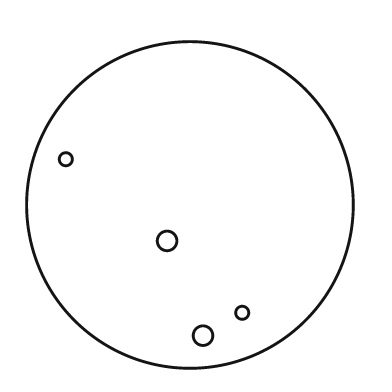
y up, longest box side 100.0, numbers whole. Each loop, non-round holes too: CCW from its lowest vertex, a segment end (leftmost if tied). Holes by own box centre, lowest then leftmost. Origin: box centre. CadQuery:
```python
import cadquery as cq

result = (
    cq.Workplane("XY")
    .moveTo(0.0, 0.0)
    .circle(50.0)
    .moveTo(4.0, -40.0)
    .circle(3.0)
    .moveTo(16.0, -33.0)
    .circle(2.0)
    .moveTo(-7.0, -11.0)
    .circle(3.0)
    .moveTo(-38.0, 14.0)
    .circle(2.0)
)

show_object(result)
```